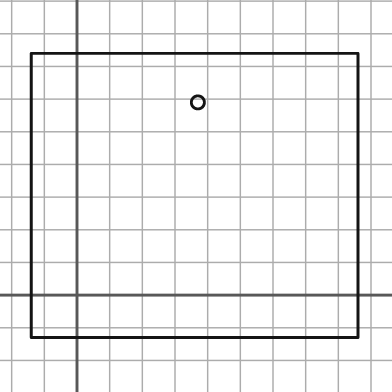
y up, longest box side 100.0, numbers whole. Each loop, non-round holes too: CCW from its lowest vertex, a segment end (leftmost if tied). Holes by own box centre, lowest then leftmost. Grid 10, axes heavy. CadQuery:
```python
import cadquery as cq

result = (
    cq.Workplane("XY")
    .moveTo(-14.0, -13.0)
    .lineTo(86.0, -13.0)
    .lineTo(86.0, 74.0)
    .lineTo(-14.0, 74.0)
    .close()
    .moveTo(37.0, 59.0)
    .circle(2.0)
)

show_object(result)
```